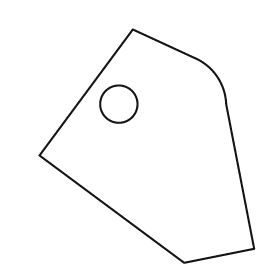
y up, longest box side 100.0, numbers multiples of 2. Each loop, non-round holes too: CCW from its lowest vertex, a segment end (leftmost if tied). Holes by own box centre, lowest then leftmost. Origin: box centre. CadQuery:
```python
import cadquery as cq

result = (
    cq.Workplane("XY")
    .moveTo(16.0, -50.0)
    .lineTo(46.0, -44.0)
    .lineTo(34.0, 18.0)
    .threePointArc((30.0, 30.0), (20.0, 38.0))
    .lineTo(-6.0, 50.0)
    .lineTo(-46.0, -4.0)
    .close()
    .moveTo(-12.0, 18.0)
    .circle(8.0)
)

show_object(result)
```